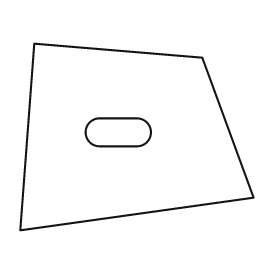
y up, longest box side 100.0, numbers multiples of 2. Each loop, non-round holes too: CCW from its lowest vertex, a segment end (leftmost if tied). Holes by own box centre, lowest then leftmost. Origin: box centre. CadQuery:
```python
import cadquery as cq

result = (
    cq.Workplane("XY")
    .moveTo(-50.0, -40.0)
    .lineTo(50.0, -26.0)
    .lineTo(28.0, 34.0)
    .lineTo(-44.0, 40.0)
    .close()
    .moveTo(-16.0, -4.0)
    .lineTo(0.0, -4.0)
    .threePointArc((6.0, 2.0), (0.0, 8.0))
    .lineTo(-16.0, 8.0)
    .threePointArc((-22.0, 2.0), (-16.0, -4.0))
    .close()
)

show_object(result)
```